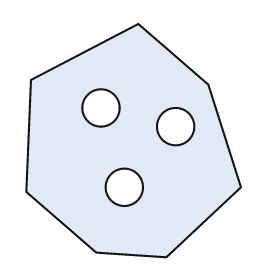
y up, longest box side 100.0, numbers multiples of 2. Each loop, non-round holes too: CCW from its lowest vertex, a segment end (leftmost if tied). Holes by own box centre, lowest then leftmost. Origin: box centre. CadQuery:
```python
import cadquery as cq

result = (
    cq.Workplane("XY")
    .moveTo(14.0, -50.0)
    .lineTo(46.0, -20.0)
    .lineTo(32.0, 24.0)
    .lineTo(2.0, 50.0)
    .lineTo(-44.0, 26.0)
    .lineTo(-46.0, -22.0)
    .lineTo(-16.0, -48.0)
    .close()
    .moveTo(-4.0, -20.0)
    .circle(8.0)
    .moveTo(18.0, 6.0)
    .circle(8.0)
    .moveTo(-14.0, 14.0)
    .circle(8.0)
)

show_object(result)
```